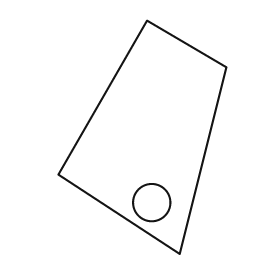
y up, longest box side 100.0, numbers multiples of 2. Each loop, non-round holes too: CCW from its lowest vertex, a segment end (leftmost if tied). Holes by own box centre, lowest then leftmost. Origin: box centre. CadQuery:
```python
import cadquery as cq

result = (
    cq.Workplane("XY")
    .moveTo(16.0, -50.0)
    .lineTo(36.0, 30.0)
    .lineTo(2.0, 50.0)
    .lineTo(-36.0, -16.0)
    .close()
    .moveTo(4.0, -28.0)
    .circle(8.0)
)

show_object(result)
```